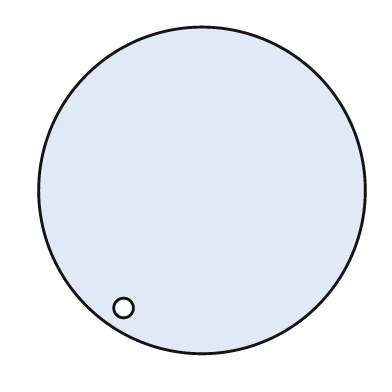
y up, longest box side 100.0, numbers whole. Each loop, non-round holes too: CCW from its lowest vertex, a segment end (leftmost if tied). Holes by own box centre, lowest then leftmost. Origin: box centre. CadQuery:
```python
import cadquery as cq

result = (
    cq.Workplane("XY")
    .moveTo(0.0, 0.0)
    .circle(50.0)
    .moveTo(-24.0, -36.0)
    .circle(3.0)
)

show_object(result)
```